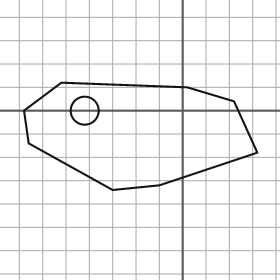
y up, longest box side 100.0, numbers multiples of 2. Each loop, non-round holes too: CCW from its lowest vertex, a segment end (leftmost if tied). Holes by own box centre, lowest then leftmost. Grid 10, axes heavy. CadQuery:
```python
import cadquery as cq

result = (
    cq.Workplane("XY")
    .moveTo(-30.0, -34.0)
    .lineTo(-10.0, -32.0)
    .lineTo(32.0, -18.0)
    .lineTo(22.0, 4.0)
    .lineTo(2.0, 10.0)
    .lineTo(-52.0, 12.0)
    .lineTo(-68.0, 0.0)
    .lineTo(-66.0, -14.0)
    .close()
    .moveTo(-42.0, 0.0)
    .circle(6.0)
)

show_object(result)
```